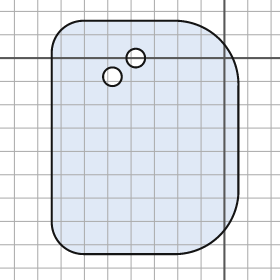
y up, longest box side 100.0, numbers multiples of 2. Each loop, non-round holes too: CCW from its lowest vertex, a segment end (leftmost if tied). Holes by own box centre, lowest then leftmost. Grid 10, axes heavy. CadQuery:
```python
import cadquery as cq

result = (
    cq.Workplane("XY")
    .moveTo(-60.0, -84.0)
    .lineTo(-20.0, -84.0)
    .threePointArc((-2.0, -76.0), (6.0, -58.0))
    .lineTo(6.0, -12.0)
    .threePointArc((-2.0, 8.0), (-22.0, 16.0))
    .lineTo(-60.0, 16.0)
    .threePointArc((-70.0, 12.0), (-74.0, 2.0))
    .lineTo(-74.0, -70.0)
    .threePointArc((-70.0, -80.0), (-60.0, -84.0))
    .close()
    .moveTo(-48.0, -8.0)
    .circle(4.0)
    .moveTo(-38.0, 0.0)
    .circle(4.0)
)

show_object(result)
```